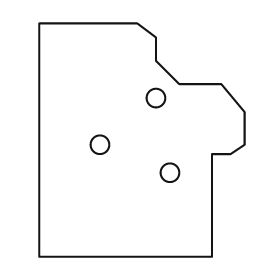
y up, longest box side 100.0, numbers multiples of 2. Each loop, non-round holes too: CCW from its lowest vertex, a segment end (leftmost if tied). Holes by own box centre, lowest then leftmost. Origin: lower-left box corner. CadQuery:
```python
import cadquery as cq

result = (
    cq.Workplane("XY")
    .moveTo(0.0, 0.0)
    .lineTo(74.0, 0.0)
    .lineTo(74.0, 44.0)
    .lineTo(82.0, 44.0)
    .lineTo(88.0, 48.0)
    .lineTo(88.0, 62.0)
    .lineTo(78.0, 74.0)
    .lineTo(60.0, 74.0)
    .lineTo(50.0, 84.0)
    .lineTo(50.0, 94.0)
    .lineTo(42.0, 100.0)
    .lineTo(0.0, 100.0)
    .close()
    .moveTo(56.0, 36.0)
    .circle(4.0)
    .moveTo(26.0, 48.0)
    .circle(4.0)
    .moveTo(50.0, 68.0)
    .circle(4.0)
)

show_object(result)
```